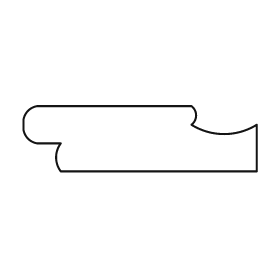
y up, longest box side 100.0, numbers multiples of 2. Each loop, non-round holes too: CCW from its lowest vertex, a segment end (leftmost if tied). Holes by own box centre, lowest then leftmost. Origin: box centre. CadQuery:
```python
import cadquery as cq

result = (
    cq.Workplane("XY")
    .moveTo(-34.0, -14.0)
    .lineTo(50.0, -14.0)
    .lineTo(50.0, 6.0)
    .threePointArc((36.0, 2.0), (22.0, 6.0))
    .threePointArc((24.0, 10.0), (22.0, 14.0))
    .lineTo(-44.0, 14.0)
    .threePointArc((-48.0, 12.0), (-50.0, 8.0))
    .lineTo(-50.0, 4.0)
    .threePointArc((-48.0, 0.0), (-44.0, -2.0))
    .lineTo(-34.0, -2.0)
    .threePointArc((-36.0, -8.0), (-34.0, -14.0))
    .close()
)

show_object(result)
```